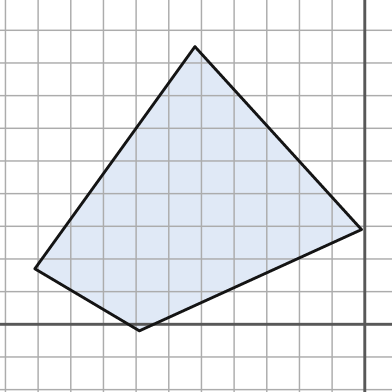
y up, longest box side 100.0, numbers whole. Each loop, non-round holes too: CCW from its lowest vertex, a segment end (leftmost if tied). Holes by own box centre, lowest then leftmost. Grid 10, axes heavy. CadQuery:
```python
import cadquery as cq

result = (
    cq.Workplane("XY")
    .moveTo(-69.0, -2.0)
    .lineTo(-1.0, 29.0)
    .lineTo(-52.0, 85.0)
    .lineTo(-101.0, 17.0)
    .close()
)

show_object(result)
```